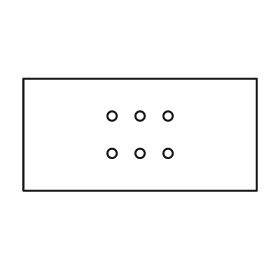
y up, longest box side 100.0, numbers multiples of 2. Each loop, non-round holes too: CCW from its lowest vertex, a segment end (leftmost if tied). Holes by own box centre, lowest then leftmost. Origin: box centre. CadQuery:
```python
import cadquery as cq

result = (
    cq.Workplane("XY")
    .moveTo(-50.0, -24.0)
    .lineTo(50.0, -24.0)
    .lineTo(50.0, 24.0)
    .lineTo(-50.0, 24.0)
    .close()
    .moveTo(-12.0, -8.0)
    .circle(2.0)
    .moveTo(0.0, -8.0)
    .circle(2.0)
    .moveTo(12.0, -8.0)
    .circle(2.0)
    .moveTo(-12.0, 8.0)
    .circle(2.0)
    .moveTo(0.0, 8.0)
    .circle(2.0)
    .moveTo(12.0, 8.0)
    .circle(2.0)
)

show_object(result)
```